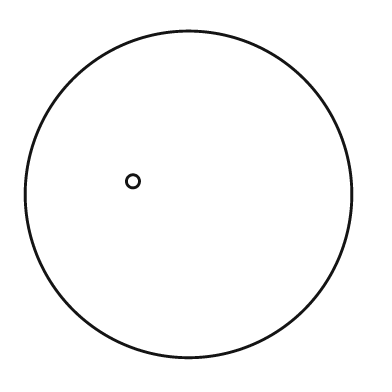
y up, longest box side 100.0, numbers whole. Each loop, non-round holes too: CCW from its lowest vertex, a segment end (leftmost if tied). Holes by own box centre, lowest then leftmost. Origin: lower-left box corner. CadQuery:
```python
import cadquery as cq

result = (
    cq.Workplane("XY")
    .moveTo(50.0, 50.0)
    .circle(50.0)
    .moveTo(33.0, 54.0)
    .circle(2.0)
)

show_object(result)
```